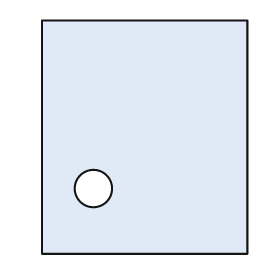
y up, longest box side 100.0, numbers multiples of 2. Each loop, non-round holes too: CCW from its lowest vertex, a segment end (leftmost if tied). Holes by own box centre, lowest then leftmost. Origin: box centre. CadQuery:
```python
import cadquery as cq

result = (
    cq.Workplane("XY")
    .moveTo(-44.0, -50.0)
    .lineTo(44.0, -50.0)
    .lineTo(44.0, 50.0)
    .lineTo(-44.0, 50.0)
    .close()
    .moveTo(-22.0, -22.0)
    .circle(8.0)
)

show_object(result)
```